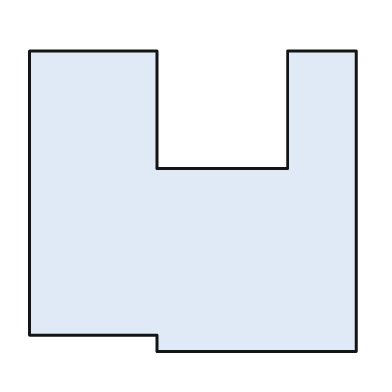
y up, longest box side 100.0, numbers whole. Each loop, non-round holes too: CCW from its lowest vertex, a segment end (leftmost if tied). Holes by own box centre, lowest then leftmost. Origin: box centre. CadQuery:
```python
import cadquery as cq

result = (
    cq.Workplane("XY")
    .moveTo(-11.0, -46.0)
    .lineTo(50.0, -46.0)
    .lineTo(50.0, 46.0)
    .lineTo(29.0, 46.0)
    .lineTo(29.0, 10.0)
    .lineTo(-11.0, 10.0)
    .lineTo(-11.0, 46.0)
    .lineTo(-50.0, 46.0)
    .lineTo(-50.0, -41.0)
    .lineTo(-11.0, -41.0)
    .close()
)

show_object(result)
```